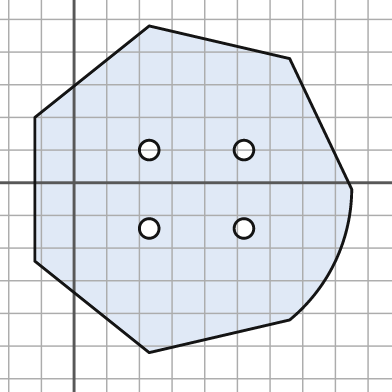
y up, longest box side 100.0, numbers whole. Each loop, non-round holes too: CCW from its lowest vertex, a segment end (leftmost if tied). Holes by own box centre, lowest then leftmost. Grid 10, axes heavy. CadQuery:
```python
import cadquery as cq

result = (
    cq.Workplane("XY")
    .moveTo(23.0, -52.0)
    .lineTo(66.0, -42.0)
    .threePointArc((80.0, -24.0), (85.0, -2.0))
    .lineTo(66.0, 38.0)
    .lineTo(23.0, 48.0)
    .lineTo(-12.0, 20.0)
    .lineTo(-12.0, -24.0)
    .close()
    .moveTo(23.0, -14.0)
    .circle(3.0)
    .moveTo(52.0, -14.0)
    .circle(3.0)
    .moveTo(23.0, 10.0)
    .circle(3.0)
    .moveTo(52.0, 10.0)
    .circle(3.0)
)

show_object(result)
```